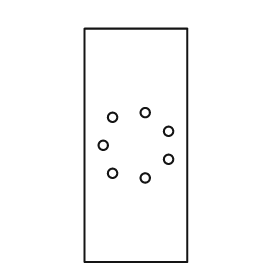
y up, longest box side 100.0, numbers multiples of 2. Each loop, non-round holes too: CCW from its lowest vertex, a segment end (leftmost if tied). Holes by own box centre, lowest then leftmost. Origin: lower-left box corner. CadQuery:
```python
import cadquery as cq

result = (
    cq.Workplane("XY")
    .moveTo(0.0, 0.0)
    .lineTo(44.0, 0.0)
    .lineTo(44.0, 100.0)
    .lineTo(0.0, 100.0)
    .close()
    .moveTo(26.0, 36.0)
    .circle(2.0)
    .moveTo(12.0, 38.0)
    .circle(2.0)
    .moveTo(36.0, 44.0)
    .circle(2.0)
    .moveTo(8.0, 50.0)
    .circle(2.0)
    .moveTo(36.0, 56.0)
    .circle(2.0)
    .moveTo(12.0, 62.0)
    .circle(2.0)
    .moveTo(26.0, 64.0)
    .circle(2.0)
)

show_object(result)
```